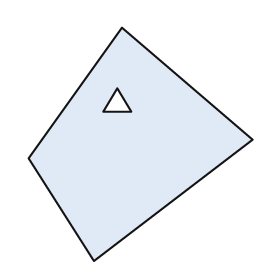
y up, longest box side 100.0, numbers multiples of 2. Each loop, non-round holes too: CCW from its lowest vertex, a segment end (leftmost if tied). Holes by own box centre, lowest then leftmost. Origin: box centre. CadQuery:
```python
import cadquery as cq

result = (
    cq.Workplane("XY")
    .moveTo(-20.0, -50.0)
    .lineTo(48.0, 2.0)
    .lineTo(-8.0, 50.0)
    .lineTo(-48.0, -6.0)
    .close()
    .moveTo(-16.0, 14.0)
    .lineTo(-4.0, 14.0)
    .lineTo(-10.0, 24.0)
    .close()
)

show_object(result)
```